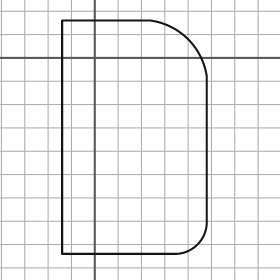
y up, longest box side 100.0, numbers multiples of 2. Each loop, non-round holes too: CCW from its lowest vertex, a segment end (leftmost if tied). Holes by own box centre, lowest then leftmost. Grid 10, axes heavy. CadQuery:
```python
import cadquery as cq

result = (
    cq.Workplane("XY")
    .moveTo(-14.0, -84.0)
    .lineTo(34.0, -84.0)
    .threePointArc((44.0, -80.0), (48.0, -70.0))
    .lineTo(48.0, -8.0)
    .threePointArc((40.0, 8.0), (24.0, 16.0))
    .lineTo(-14.0, 16.0)
    .close()
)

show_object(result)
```